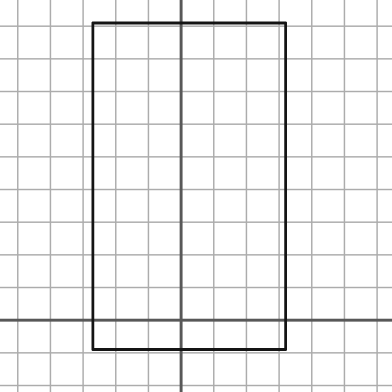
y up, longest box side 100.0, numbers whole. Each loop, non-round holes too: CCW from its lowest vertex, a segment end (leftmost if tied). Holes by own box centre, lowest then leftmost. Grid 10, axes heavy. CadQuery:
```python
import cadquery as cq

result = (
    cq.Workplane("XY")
    .moveTo(-27.0, -9.0)
    .lineTo(32.0, -9.0)
    .lineTo(32.0, 91.0)
    .lineTo(-27.0, 91.0)
    .close()
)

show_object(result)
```